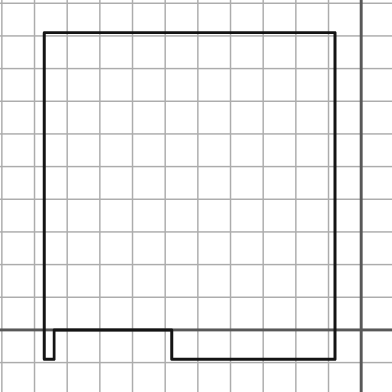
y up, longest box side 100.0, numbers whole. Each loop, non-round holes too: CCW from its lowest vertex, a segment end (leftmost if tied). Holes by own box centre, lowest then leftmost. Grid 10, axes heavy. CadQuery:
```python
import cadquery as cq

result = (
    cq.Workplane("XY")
    .moveTo(-97.0, -9.0)
    .lineTo(-94.0, -9.0)
    .lineTo(-94.0, 0.0)
    .lineTo(-58.0, 0.0)
    .lineTo(-58.0, -9.0)
    .lineTo(-8.0, -9.0)
    .lineTo(-8.0, 91.0)
    .lineTo(-97.0, 91.0)
    .close()
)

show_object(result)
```